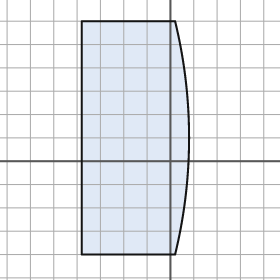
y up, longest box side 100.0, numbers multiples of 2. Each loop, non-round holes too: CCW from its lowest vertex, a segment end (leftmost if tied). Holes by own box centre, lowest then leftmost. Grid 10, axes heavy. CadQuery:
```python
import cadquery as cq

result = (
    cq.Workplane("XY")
    .moveTo(-38.0, -40.0)
    .lineTo(2.0, -40.0)
    .threePointArc((8.0, 10.0), (2.0, 60.0))
    .lineTo(-38.0, 60.0)
    .close()
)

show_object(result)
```